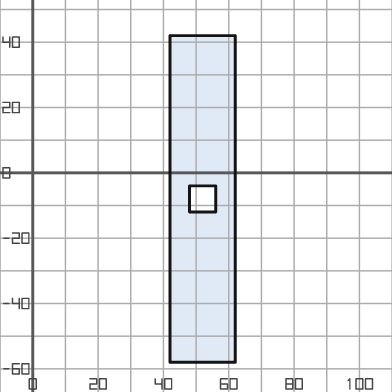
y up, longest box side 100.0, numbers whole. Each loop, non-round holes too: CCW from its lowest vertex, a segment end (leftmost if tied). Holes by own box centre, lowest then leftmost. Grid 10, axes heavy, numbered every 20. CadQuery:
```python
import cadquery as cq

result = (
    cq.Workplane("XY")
    .moveTo(42.0, -58.0)
    .lineTo(62.0, -58.0)
    .lineTo(62.0, 42.0)
    .lineTo(42.0, 42.0)
    .close()
    .moveTo(48.0, -12.0)
    .lineTo(56.0, -12.0)
    .lineTo(56.0, -4.0)
    .lineTo(48.0, -4.0)
    .close()
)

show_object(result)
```